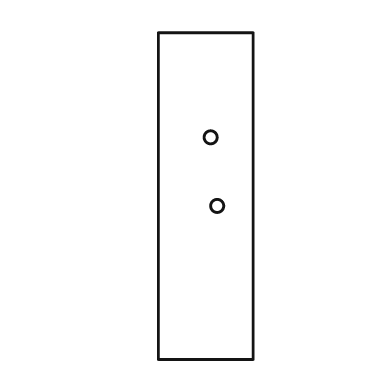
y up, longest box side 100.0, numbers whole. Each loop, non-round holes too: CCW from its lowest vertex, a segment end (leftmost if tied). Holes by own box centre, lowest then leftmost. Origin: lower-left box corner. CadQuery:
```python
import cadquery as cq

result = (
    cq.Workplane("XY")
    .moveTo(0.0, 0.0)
    .lineTo(29.0, 0.0)
    .lineTo(29.0, 100.0)
    .lineTo(0.0, 100.0)
    .close()
    .moveTo(18.0, 47.0)
    .circle(2.0)
    .moveTo(16.0, 68.0)
    .circle(2.0)
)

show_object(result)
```